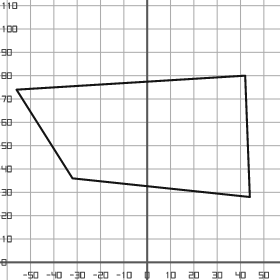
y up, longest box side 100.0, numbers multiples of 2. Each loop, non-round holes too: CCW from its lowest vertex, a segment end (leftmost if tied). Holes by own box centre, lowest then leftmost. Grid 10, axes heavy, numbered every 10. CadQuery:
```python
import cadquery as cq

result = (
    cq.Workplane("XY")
    .moveTo(44.0, 28.0)
    .lineTo(42.0, 80.0)
    .lineTo(-56.0, 74.0)
    .lineTo(-32.0, 36.0)
    .close()
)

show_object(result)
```